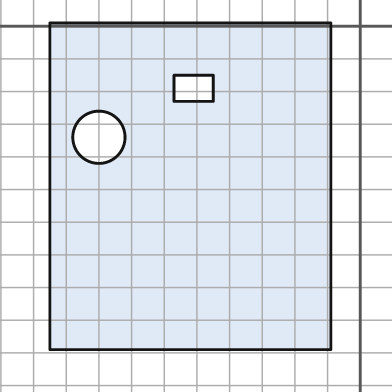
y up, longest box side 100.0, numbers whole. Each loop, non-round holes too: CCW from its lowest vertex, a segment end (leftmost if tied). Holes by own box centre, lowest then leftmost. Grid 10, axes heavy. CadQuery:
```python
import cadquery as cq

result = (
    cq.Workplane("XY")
    .moveTo(-95.0, -99.0)
    .lineTo(-9.0, -99.0)
    .lineTo(-9.0, 1.0)
    .lineTo(-95.0, 1.0)
    .close()
    .moveTo(-80.0, -34.0)
    .circle(8.0)
    .moveTo(-57.0, -23.0)
    .lineTo(-45.0, -23.0)
    .lineTo(-45.0, -15.0)
    .lineTo(-57.0, -15.0)
    .close()
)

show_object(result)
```